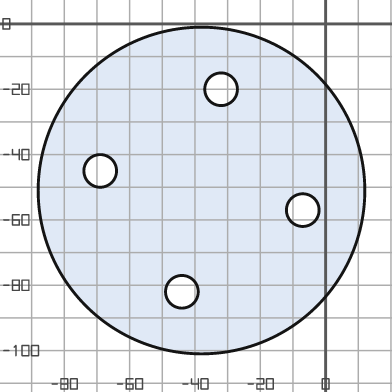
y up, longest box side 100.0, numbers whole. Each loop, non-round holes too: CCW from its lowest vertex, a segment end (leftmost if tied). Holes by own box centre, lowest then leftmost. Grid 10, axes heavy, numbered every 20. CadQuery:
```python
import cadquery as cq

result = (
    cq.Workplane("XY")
    .moveTo(-38.0, -51.0)
    .circle(50.0)
    .moveTo(-44.0, -82.0)
    .circle(5.0)
    .moveTo(-7.0, -57.0)
    .circle(5.0)
    .moveTo(-69.0, -45.0)
    .circle(5.0)
    .moveTo(-32.0, -20.0)
    .circle(5.0)
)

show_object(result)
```